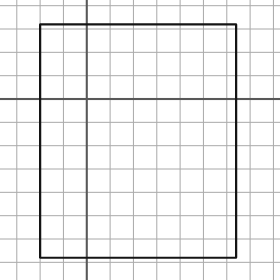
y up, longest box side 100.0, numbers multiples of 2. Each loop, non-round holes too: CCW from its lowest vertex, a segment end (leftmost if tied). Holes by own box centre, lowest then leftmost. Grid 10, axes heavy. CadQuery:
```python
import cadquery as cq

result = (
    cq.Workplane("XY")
    .moveTo(-20.0, -68.0)
    .lineTo(64.0, -68.0)
    .lineTo(64.0, 32.0)
    .lineTo(-20.0, 32.0)
    .close()
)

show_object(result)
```